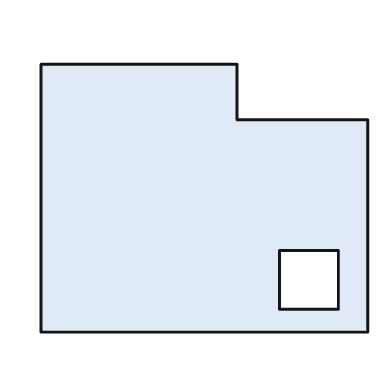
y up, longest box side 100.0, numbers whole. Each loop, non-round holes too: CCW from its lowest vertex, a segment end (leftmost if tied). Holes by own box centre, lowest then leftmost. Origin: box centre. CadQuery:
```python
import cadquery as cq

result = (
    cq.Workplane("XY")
    .moveTo(-50.0, -41.0)
    .lineTo(50.0, -41.0)
    .lineTo(50.0, 24.0)
    .lineTo(10.0, 24.0)
    .lineTo(10.0, 41.0)
    .lineTo(-50.0, 41.0)
    .close()
    .moveTo(23.0, -34.0)
    .lineTo(41.0, -34.0)
    .lineTo(41.0, -16.0)
    .lineTo(23.0, -16.0)
    .close()
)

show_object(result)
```